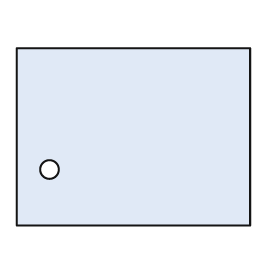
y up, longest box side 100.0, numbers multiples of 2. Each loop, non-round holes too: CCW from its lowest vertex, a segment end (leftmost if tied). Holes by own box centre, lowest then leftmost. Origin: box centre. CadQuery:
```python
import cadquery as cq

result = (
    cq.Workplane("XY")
    .moveTo(-50.0, -38.0)
    .lineTo(50.0, -38.0)
    .lineTo(50.0, 38.0)
    .lineTo(-50.0, 38.0)
    .close()
    .moveTo(-36.0, -14.0)
    .circle(4.0)
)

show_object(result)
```